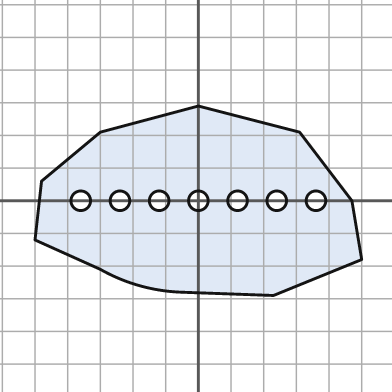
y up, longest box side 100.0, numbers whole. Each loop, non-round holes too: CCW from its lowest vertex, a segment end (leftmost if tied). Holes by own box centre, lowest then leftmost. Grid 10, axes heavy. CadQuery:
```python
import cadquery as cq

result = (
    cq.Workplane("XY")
    .moveTo(23.0, -29.0)
    .lineTo(50.0, -18.0)
    .lineTo(47.0, 0.0)
    .lineTo(31.0, 21.0)
    .lineTo(0.0, 29.0)
    .lineTo(-30.0, 21.0)
    .lineTo(-48.0, 6.0)
    .lineTo(-50.0, -12.0)
    .lineTo(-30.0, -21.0)
    .threePointArc((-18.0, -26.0), (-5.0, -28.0))
    .close()
    .moveTo(-36.0, 0.0)
    .circle(3.0)
    .moveTo(-24.0, 0.0)
    .circle(3.0)
    .moveTo(-12.0, 0.0)
    .circle(3.0)
    .moveTo(0.0, 0.0)
    .circle(3.0)
    .moveTo(12.0, 0.0)
    .circle(3.0)
    .moveTo(24.0, 0.0)
    .circle(3.0)
    .moveTo(36.0, 0.0)
    .circle(3.0)
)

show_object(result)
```